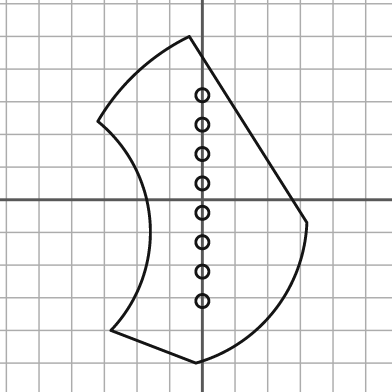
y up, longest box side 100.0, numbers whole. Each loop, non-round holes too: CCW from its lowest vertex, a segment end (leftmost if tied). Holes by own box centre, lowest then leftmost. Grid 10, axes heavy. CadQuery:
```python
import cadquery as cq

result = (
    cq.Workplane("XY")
    .moveTo(-2.0, -50.0)
    .threePointArc((22.0, -34.0), (32.0, -7.0))
    .lineTo(-4.0, 50.0)
    .threePointArc((-20.0, 39.0), (-32.0, 24.0))
    .threePointArc((-16.0, -7.0), (-28.0, -40.0))
    .close()
    .moveTo(0.0, -31.0)
    .circle(2.0)
    .moveTo(0.0, -22.0)
    .circle(2.0)
    .moveTo(0.0, -13.0)
    .circle(2.0)
    .moveTo(0.0, -4.0)
    .circle(2.0)
    .moveTo(0.0, 5.0)
    .circle(2.0)
    .moveTo(0.0, 14.0)
    .circle(2.0)
    .moveTo(0.0, 23.0)
    .circle(2.0)
    .moveTo(0.0, 32.0)
    .circle(2.0)
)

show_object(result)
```